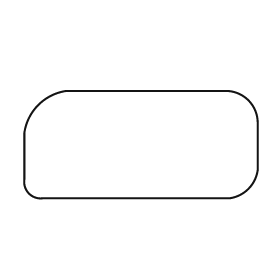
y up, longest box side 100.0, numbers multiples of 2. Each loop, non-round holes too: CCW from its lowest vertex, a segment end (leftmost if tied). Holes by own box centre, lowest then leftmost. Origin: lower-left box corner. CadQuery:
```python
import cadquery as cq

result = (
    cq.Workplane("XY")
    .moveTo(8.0, 0.0)
    .lineTo(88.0, 0.0)
    .threePointArc((96.0, 4.0), (100.0, 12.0))
    .lineTo(100.0, 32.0)
    .threePointArc((96.0, 42.0), (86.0, 46.0))
    .lineTo(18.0, 46.0)
    .threePointArc((6.0, 40.0), (0.0, 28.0))
    .lineTo(0.0, 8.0)
    .threePointArc((2.0, 2.0), (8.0, 0.0))
    .close()
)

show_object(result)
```